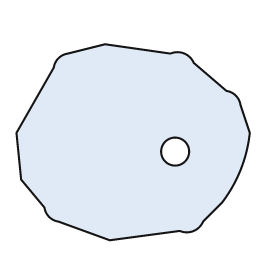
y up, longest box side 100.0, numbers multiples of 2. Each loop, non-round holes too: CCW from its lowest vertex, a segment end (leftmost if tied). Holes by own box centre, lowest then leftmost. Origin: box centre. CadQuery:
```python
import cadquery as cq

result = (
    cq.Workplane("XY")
    .moveTo(-10.0, -42.0)
    .lineTo(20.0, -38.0)
    .threePointArc((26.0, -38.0), (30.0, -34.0))
    .lineTo(38.0, -26.0)
    .threePointArc((46.0, -12.0), (50.0, 4.0))
    .lineTo(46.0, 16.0)
    .threePointArc((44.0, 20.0), (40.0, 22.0))
    .lineTo(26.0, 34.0)
    .threePointArc((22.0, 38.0), (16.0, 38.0))
    .lineTo(-12.0, 42.0)
    .lineTo(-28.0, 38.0)
    .threePointArc((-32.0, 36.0), (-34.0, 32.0))
    .lineTo(-50.0, 4.0)
    .lineTo(-48.0, -16.0)
    .lineTo(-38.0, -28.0)
    .threePointArc((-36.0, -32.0), (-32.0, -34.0))
    .close()
    .moveTo(18.0, -4.0)
    .circle(6.0)
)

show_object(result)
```